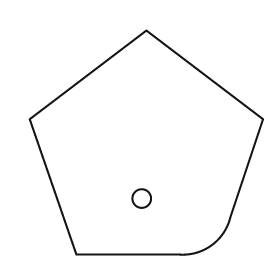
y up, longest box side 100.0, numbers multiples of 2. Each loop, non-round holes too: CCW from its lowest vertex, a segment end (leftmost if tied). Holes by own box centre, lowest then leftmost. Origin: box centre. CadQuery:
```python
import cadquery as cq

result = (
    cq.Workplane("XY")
    .moveTo(-30.0, -48.0)
    .lineTo(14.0, -48.0)
    .threePointArc((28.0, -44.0), (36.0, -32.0))
    .lineTo(50.0, 10.0)
    .lineTo(0.0, 48.0)
    .lineTo(-50.0, 10.0)
    .close()
    .moveTo(-2.0, -24.0)
    .circle(4.0)
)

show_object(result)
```